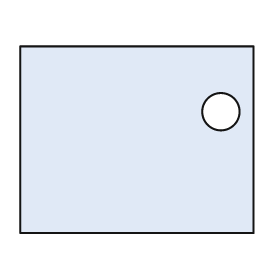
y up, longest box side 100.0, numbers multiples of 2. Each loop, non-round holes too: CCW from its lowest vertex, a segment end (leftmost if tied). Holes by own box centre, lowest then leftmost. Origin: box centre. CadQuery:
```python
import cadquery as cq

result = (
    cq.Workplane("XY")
    .moveTo(-50.0, -40.0)
    .lineTo(50.0, -40.0)
    .lineTo(50.0, 40.0)
    .lineTo(-50.0, 40.0)
    .close()
    .moveTo(36.0, 12.0)
    .circle(8.0)
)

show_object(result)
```